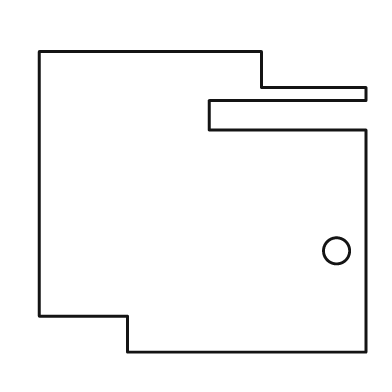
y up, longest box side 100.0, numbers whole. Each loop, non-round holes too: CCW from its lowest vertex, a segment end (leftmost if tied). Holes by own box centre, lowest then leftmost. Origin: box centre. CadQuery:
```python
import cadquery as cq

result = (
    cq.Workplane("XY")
    .moveTo(-23.0, -46.0)
    .lineTo(50.0, -46.0)
    .lineTo(50.0, 22.0)
    .lineTo(2.0, 22.0)
    .lineTo(2.0, 31.0)
    .lineTo(50.0, 31.0)
    .lineTo(50.0, 35.0)
    .lineTo(18.0, 35.0)
    .lineTo(18.0, 46.0)
    .lineTo(-50.0, 46.0)
    .lineTo(-50.0, -35.0)
    .lineTo(-23.0, -35.0)
    .close()
    .moveTo(41.0, -15.0)
    .circle(4.0)
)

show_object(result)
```